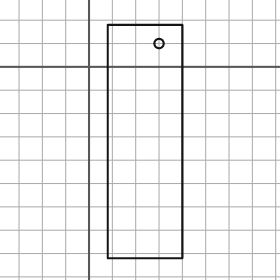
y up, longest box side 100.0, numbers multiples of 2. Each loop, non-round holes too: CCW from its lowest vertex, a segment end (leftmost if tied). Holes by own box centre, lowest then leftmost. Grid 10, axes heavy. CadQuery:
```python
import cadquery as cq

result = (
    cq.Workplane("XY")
    .moveTo(8.0, -82.0)
    .lineTo(40.0, -82.0)
    .lineTo(40.0, 18.0)
    .lineTo(8.0, 18.0)
    .close()
    .moveTo(30.0, 10.0)
    .circle(2.0)
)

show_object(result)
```